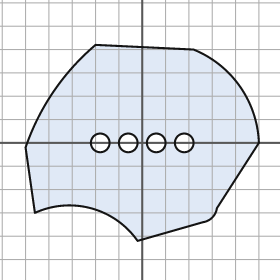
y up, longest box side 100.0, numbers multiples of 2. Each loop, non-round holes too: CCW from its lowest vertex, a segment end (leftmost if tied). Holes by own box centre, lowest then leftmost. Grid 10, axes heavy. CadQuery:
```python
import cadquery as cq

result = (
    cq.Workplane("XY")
    .moveTo(-2.0, -42.0)
    .lineTo(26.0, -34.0)
    .threePointArc((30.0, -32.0), (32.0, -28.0))
    .lineTo(50.0, 0.0)
    .threePointArc((42.0, 24.0), (22.0, 40.0))
    .lineTo(-20.0, 42.0)
    .threePointArc((-38.0, 22.0), (-50.0, -2.0))
    .lineTo(-46.0, -30.0)
    .threePointArc((-22.0, -28.0), (-2.0, -42.0))
    .close()
    .moveTo(-18.0, 0.0)
    .circle(4.0)
    .moveTo(-6.0, 0.0)
    .circle(4.0)
    .moveTo(6.0, 0.0)
    .circle(4.0)
    .moveTo(18.0, 0.0)
    .circle(4.0)
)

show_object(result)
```